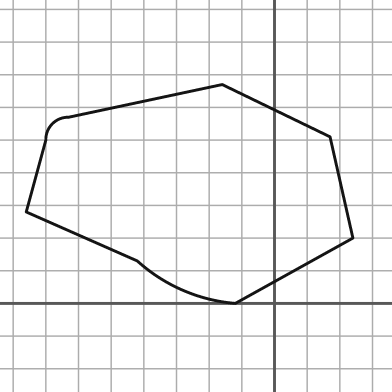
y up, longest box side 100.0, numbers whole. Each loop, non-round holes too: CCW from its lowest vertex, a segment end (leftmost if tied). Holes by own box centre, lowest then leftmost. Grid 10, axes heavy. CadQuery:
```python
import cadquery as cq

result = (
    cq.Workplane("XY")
    .moveTo(-12.0, 0.0)
    .lineTo(24.0, 20.0)
    .lineTo(17.0, 51.0)
    .lineTo(-16.0, 67.0)
    .lineTo(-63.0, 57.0)
    .threePointArc((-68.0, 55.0), (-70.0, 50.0))
    .lineTo(-76.0, 28.0)
    .lineTo(-42.0, 13.0)
    .threePointArc((-28.0, 4.0), (-12.0, 0.0))
    .close()
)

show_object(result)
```